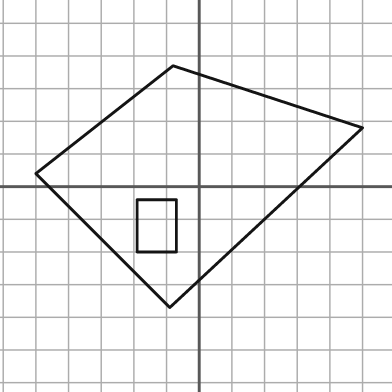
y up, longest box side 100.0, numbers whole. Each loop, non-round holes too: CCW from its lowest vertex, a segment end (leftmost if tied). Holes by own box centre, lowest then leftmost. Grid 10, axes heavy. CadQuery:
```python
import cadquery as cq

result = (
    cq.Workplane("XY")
    .moveTo(-9.0, -37.0)
    .lineTo(50.0, 18.0)
    .lineTo(-8.0, 37.0)
    .lineTo(-50.0, 4.0)
    .close()
    .moveTo(-19.0, -20.0)
    .lineTo(-7.0, -20.0)
    .lineTo(-7.0, -4.0)
    .lineTo(-19.0, -4.0)
    .close()
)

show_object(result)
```